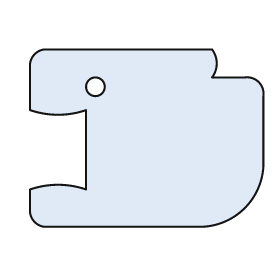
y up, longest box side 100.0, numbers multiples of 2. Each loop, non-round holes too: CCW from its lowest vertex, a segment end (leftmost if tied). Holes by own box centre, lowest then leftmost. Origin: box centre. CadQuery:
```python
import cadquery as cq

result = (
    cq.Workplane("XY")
    .moveTo(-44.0, -38.0)
    .lineTo(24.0, -38.0)
    .threePointArc((42.0, -30.0), (50.0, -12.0))
    .lineTo(50.0, 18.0)
    .threePointArc((48.0, 24.0), (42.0, 26.0))
    .lineTo(28.0, 26.0)
    .threePointArc((30.0, 32.0), (28.0, 38.0))
    .lineTo(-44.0, 38.0)
    .threePointArc((-48.0, 36.0), (-50.0, 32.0))
    .lineTo(-50.0, 12.0)
    .threePointArc((-38.0, 10.0), (-26.0, 12.0))
    .lineTo(-26.0, -22.0)
    .threePointArc((-38.0, -20.0), (-50.0, -22.0))
    .lineTo(-50.0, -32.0)
    .threePointArc((-48.0, -36.0), (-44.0, -38.0))
    .close()
    .moveTo(-22.0, 22.0)
    .circle(4.0)
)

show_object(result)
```